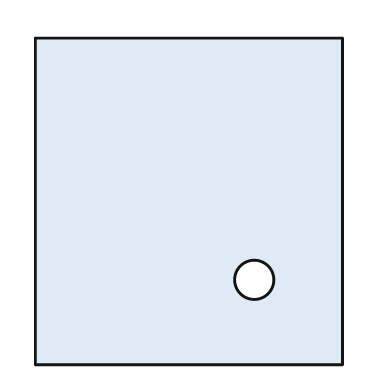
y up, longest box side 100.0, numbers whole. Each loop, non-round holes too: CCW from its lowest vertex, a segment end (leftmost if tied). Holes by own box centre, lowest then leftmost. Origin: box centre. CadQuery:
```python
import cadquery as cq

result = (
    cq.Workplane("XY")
    .moveTo(-47.0, -50.0)
    .lineTo(47.0, -50.0)
    .lineTo(47.0, 50.0)
    .lineTo(-47.0, 50.0)
    .close()
    .moveTo(20.0, -24.0)
    .circle(6.0)
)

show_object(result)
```